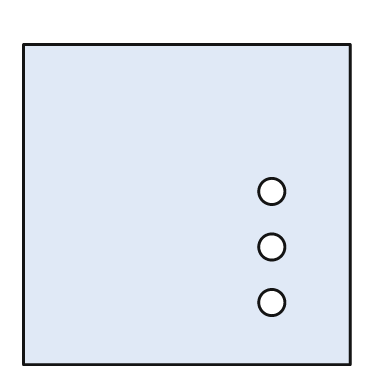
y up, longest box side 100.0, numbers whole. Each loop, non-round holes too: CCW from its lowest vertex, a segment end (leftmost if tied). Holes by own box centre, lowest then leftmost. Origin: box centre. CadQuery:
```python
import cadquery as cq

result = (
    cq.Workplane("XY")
    .moveTo(-50.0, -49.0)
    .lineTo(50.0, -49.0)
    .lineTo(50.0, 49.0)
    .lineTo(-50.0, 49.0)
    .close()
    .moveTo(26.0, -30.0)
    .circle(4.0)
    .moveTo(26.0, -13.0)
    .circle(4.0)
    .moveTo(26.0, 4.0)
    .circle(4.0)
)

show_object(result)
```